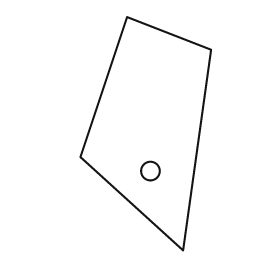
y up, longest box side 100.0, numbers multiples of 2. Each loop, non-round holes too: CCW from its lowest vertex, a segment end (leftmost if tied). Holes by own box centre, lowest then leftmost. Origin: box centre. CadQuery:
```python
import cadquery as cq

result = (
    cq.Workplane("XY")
    .moveTo(16.0, -50.0)
    .lineTo(28.0, 36.0)
    .lineTo(-8.0, 50.0)
    .lineTo(-28.0, -10.0)
    .close()
    .moveTo(2.0, -16.0)
    .circle(4.0)
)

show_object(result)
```